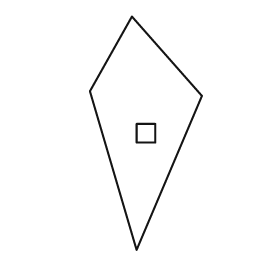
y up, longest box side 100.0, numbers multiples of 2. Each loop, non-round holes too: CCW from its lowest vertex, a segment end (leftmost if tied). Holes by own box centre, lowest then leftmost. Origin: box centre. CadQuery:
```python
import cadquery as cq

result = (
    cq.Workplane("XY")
    .moveTo(-4.0, -50.0)
    .lineTo(24.0, 16.0)
    .lineTo(-6.0, 50.0)
    .lineTo(-24.0, 18.0)
    .close()
    .moveTo(-4.0, -4.0)
    .lineTo(4.0, -4.0)
    .lineTo(4.0, 4.0)
    .lineTo(-4.0, 4.0)
    .close()
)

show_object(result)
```